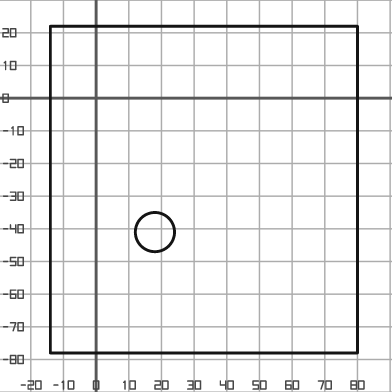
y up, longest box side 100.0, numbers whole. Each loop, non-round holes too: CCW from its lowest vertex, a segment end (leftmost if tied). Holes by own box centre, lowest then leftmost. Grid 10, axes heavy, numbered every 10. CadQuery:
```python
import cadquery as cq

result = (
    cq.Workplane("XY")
    .moveTo(-14.0, -78.0)
    .lineTo(80.0, -78.0)
    .lineTo(80.0, 22.0)
    .lineTo(-14.0, 22.0)
    .close()
    .moveTo(18.0, -41.0)
    .circle(6.0)
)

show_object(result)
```